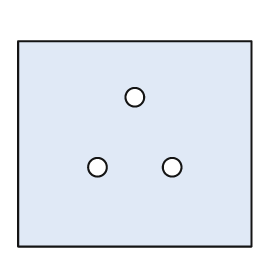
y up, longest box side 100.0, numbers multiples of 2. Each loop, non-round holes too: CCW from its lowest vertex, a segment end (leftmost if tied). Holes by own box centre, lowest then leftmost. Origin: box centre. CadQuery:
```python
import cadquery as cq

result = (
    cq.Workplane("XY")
    .moveTo(-50.0, -44.0)
    .lineTo(50.0, -44.0)
    .lineTo(50.0, 44.0)
    .lineTo(-50.0, 44.0)
    .close()
    .moveTo(-16.0, -10.0)
    .circle(4.0)
    .moveTo(16.0, -10.0)
    .circle(4.0)
    .moveTo(0.0, 20.0)
    .circle(4.0)
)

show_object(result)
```